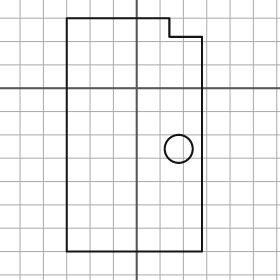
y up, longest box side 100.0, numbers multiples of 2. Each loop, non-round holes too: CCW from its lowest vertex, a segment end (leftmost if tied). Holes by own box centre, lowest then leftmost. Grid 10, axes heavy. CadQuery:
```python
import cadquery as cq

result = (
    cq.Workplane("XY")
    .moveTo(-30.0, -70.0)
    .lineTo(28.0, -70.0)
    .lineTo(28.0, 22.0)
    .lineTo(14.0, 22.0)
    .lineTo(14.0, 30.0)
    .lineTo(-30.0, 30.0)
    .close()
    .moveTo(18.0, -26.0)
    .circle(6.0)
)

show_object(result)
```